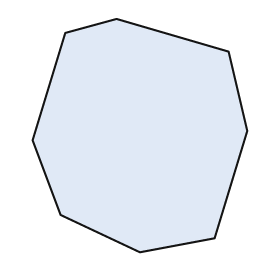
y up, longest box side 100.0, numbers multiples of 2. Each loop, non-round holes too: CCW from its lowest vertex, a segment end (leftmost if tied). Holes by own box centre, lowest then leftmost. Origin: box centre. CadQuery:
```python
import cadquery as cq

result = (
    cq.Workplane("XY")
    .moveTo(0.0, -50.0)
    .lineTo(32.0, -44.0)
    .lineTo(46.0, 2.0)
    .lineTo(38.0, 36.0)
    .lineTo(-10.0, 50.0)
    .lineTo(-32.0, 44.0)
    .lineTo(-46.0, -2.0)
    .lineTo(-34.0, -34.0)
    .close()
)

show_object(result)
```